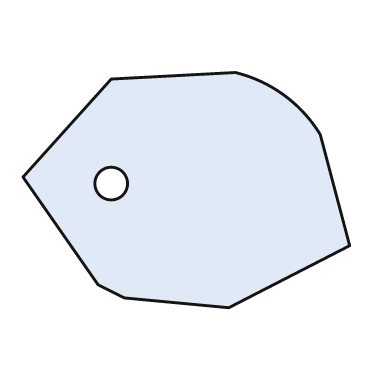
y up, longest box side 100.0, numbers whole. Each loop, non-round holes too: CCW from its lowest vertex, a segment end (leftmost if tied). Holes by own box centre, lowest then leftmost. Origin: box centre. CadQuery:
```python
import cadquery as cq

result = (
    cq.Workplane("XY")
    .moveTo(13.0, -36.0)
    .lineTo(50.0, -17.0)
    .lineTo(41.0, 17.0)
    .threePointArc((30.0, 29.0), (15.0, 36.0))
    .lineTo(-23.0, 34.0)
    .lineTo(-50.0, 4.0)
    .lineTo(-27.0, -29.0)
    .lineTo(-19.0, -33.0)
    .close()
    .moveTo(-23.0, 2.0)
    .circle(5.0)
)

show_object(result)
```